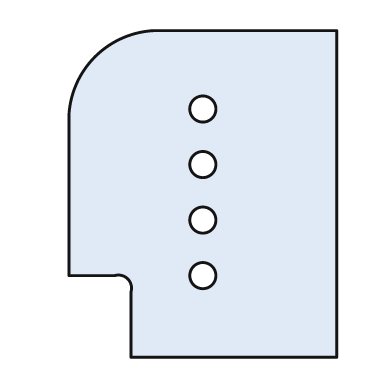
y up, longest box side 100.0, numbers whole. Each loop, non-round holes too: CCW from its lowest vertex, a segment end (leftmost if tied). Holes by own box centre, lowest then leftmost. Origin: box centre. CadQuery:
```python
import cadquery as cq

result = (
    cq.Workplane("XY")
    .moveTo(-22.0, -50.0)
    .lineTo(41.0, -50.0)
    .lineTo(41.0, 50.0)
    .lineTo(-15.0, 50.0)
    .threePointArc((-33.0, 42.0), (-41.0, 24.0))
    .lineTo(-41.0, -25.0)
    .lineTo(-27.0, -25.0)
    .threePointArc((-23.0, -26.0), (-22.0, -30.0))
    .close()
    .moveTo(0.0, -25.0)
    .circle(4.0)
    .moveTo(0.0, -8.0)
    .circle(4.0)
    .moveTo(0.0, 9.0)
    .circle(4.0)
    .moveTo(0.0, 26.0)
    .circle(4.0)
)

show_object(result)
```